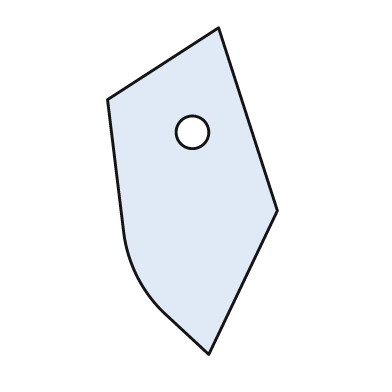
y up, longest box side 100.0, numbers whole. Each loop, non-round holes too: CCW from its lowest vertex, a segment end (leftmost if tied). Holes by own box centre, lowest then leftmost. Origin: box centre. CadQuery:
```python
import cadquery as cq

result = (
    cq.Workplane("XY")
    .moveTo(5.0, -50.0)
    .lineTo(26.0, -6.0)
    .lineTo(8.0, 50.0)
    .lineTo(-26.0, 28.0)
    .lineTo(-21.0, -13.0)
    .threePointArc((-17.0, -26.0), (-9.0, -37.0))
    .close()
    .moveTo(0.0, 18.0)
    .circle(5.0)
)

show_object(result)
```